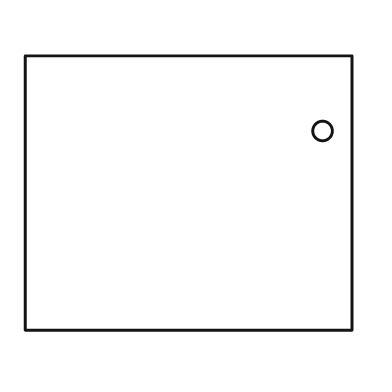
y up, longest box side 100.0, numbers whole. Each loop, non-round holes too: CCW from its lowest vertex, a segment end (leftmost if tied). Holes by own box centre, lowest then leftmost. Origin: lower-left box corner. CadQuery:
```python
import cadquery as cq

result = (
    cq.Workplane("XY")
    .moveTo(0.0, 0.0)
    .lineTo(100.0, 0.0)
    .lineTo(100.0, 84.0)
    .lineTo(0.0, 84.0)
    .close()
    .moveTo(91.0, 61.0)
    .circle(3.0)
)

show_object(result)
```